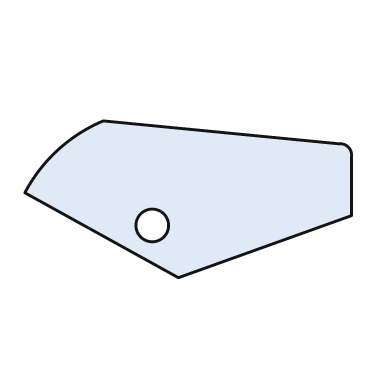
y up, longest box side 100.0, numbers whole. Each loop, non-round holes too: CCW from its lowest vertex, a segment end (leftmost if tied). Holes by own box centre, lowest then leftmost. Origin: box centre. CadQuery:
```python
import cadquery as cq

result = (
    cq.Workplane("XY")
    .moveTo(-3.0, -24.0)
    .lineTo(50.0, -5.0)
    .lineTo(50.0, 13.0)
    .threePointArc((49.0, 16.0), (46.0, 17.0))
    .lineTo(-26.0, 24.0)
    .threePointArc((-40.0, 15.0), (-50.0, 2.0))
    .close()
    .moveTo(-11.0, -8.0)
    .circle(5.0)
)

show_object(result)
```